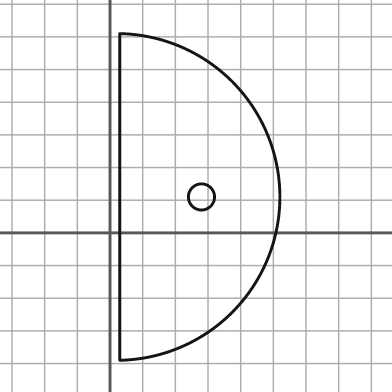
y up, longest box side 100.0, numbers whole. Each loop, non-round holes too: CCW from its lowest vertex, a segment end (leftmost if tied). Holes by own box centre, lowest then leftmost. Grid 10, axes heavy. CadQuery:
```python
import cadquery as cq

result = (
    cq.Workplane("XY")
    .moveTo(3.0, -39.0)
    .threePointArc((52.0, 11.0), (3.0, 61.0))
    .close()
    .moveTo(28.0, 11.0)
    .circle(4.0)
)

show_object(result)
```